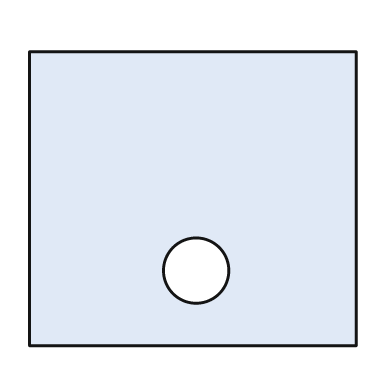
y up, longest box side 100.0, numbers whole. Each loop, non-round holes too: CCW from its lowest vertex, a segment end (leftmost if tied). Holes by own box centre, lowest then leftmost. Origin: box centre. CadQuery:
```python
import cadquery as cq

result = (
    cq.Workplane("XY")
    .moveTo(-50.0, -45.0)
    .lineTo(50.0, -45.0)
    .lineTo(50.0, 45.0)
    .lineTo(-50.0, 45.0)
    .close()
    .moveTo(1.0, -22.0)
    .circle(10.0)
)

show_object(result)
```